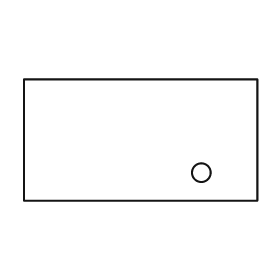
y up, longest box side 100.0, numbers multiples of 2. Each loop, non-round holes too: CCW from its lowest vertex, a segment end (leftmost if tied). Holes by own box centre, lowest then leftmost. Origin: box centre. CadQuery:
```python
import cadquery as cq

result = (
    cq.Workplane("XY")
    .moveTo(-50.0, -26.0)
    .lineTo(50.0, -26.0)
    .lineTo(50.0, 26.0)
    .lineTo(-50.0, 26.0)
    .close()
    .moveTo(26.0, -14.0)
    .circle(4.0)
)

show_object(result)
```